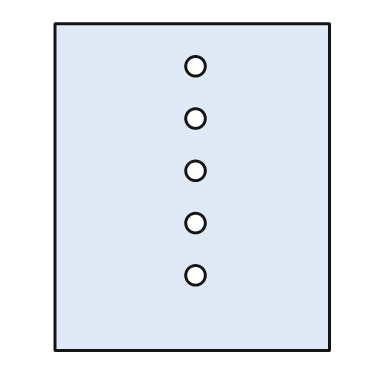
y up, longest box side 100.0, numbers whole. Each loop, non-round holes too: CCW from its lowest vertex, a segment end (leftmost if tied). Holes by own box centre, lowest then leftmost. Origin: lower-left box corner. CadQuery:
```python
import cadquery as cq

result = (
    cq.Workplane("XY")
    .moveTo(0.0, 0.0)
    .lineTo(84.0, 0.0)
    .lineTo(84.0, 100.0)
    .lineTo(0.0, 100.0)
    .close()
    .moveTo(43.0, 23.0)
    .circle(3.0)
    .moveTo(43.0, 39.0)
    .circle(3.0)
    .moveTo(43.0, 55.0)
    .circle(3.0)
    .moveTo(43.0, 71.0)
    .circle(3.0)
    .moveTo(43.0, 87.0)
    .circle(3.0)
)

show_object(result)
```